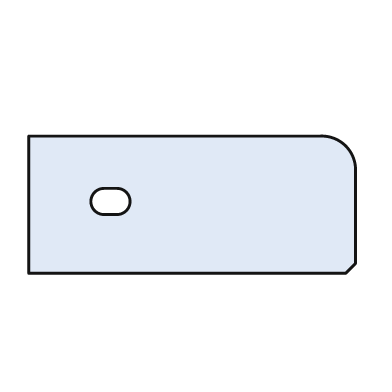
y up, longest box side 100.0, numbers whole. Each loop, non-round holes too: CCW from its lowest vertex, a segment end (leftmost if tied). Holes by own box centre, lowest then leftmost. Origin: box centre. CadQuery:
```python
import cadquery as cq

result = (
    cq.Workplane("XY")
    .moveTo(-50.0, -21.0)
    .lineTo(47.0, -21.0)
    .lineTo(50.0, -18.0)
    .lineTo(50.0, 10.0)
    .threePointArc((47.0, 18.0), (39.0, 21.0))
    .lineTo(-50.0, 21.0)
    .close()
    .moveTo(-27.0, -3.0)
    .lineTo(-23.0, -3.0)
    .threePointArc((-19.0, 1.0), (-23.0, 5.0))
    .lineTo(-27.0, 5.0)
    .threePointArc((-31.0, 1.0), (-27.0, -3.0))
    .close()
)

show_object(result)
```